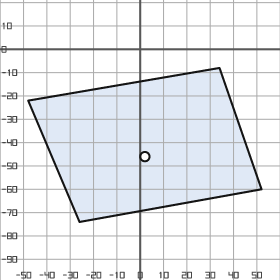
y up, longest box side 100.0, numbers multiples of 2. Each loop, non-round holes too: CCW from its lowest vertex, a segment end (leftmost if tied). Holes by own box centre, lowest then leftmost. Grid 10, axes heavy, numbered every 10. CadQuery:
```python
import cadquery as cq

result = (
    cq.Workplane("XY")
    .moveTo(-26.0, -74.0)
    .lineTo(52.0, -60.0)
    .lineTo(34.0, -8.0)
    .lineTo(-48.0, -22.0)
    .close()
    .moveTo(2.0, -46.0)
    .circle(2.0)
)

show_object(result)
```